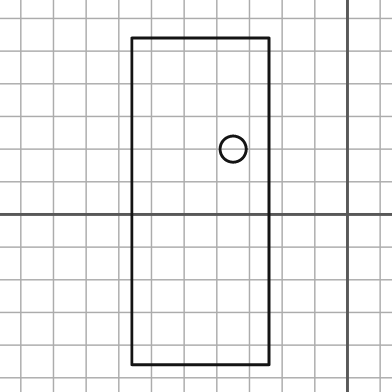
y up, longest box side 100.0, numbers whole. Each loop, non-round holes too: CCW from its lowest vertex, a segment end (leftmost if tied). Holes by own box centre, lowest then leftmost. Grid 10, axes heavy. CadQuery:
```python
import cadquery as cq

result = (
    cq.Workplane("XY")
    .moveTo(-66.0, -46.0)
    .lineTo(-24.0, -46.0)
    .lineTo(-24.0, 54.0)
    .lineTo(-66.0, 54.0)
    .close()
    .moveTo(-35.0, 20.0)
    .circle(4.0)
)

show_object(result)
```